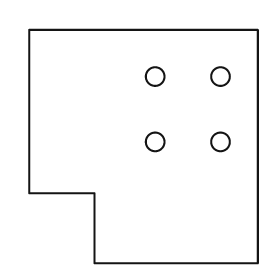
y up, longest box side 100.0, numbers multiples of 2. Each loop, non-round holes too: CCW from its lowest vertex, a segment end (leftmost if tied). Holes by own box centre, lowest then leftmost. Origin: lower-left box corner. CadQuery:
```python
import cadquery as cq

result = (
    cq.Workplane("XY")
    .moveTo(28.0, 0.0)
    .lineTo(98.0, 0.0)
    .lineTo(98.0, 100.0)
    .lineTo(0.0, 100.0)
    .lineTo(0.0, 30.0)
    .lineTo(28.0, 30.0)
    .close()
    .moveTo(54.0, 52.0)
    .circle(4.0)
    .moveTo(82.0, 52.0)
    .circle(4.0)
    .moveTo(54.0, 80.0)
    .circle(4.0)
    .moveTo(82.0, 80.0)
    .circle(4.0)
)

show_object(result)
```